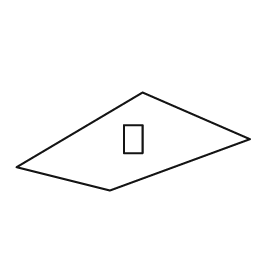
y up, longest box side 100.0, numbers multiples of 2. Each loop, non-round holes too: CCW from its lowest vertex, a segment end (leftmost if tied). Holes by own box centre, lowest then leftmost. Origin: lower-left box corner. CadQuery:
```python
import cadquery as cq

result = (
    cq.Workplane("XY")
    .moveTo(40.0, 0.0)
    .lineTo(100.0, 22.0)
    .lineTo(54.0, 42.0)
    .lineTo(0.0, 10.0)
    .close()
    .moveTo(46.0, 16.0)
    .lineTo(54.0, 16.0)
    .lineTo(54.0, 28.0)
    .lineTo(46.0, 28.0)
    .close()
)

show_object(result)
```